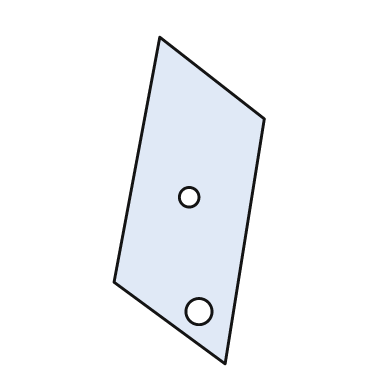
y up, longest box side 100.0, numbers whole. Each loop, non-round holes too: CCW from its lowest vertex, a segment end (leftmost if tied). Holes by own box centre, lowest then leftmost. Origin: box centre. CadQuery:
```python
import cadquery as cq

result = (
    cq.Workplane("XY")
    .moveTo(11.0, -50.0)
    .lineTo(23.0, 25.0)
    .lineTo(-9.0, 50.0)
    .lineTo(-23.0, -25.0)
    .close()
    .moveTo(3.0, -34.0)
    .circle(4.0)
    .moveTo(0.0, 1.0)
    .circle(3.0)
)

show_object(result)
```